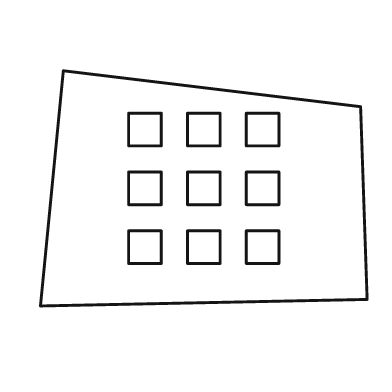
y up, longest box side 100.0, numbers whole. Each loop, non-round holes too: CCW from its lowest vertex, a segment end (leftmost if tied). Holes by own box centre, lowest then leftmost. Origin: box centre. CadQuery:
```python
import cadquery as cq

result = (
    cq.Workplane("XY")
    .moveTo(-50.0, -36.0)
    .lineTo(50.0, -34.0)
    .lineTo(48.0, 25.0)
    .lineTo(-43.0, 36.0)
    .close()
    .moveTo(-23.0, -23.0)
    .lineTo(-13.0, -23.0)
    .lineTo(-13.0, -13.0)
    .lineTo(-23.0, -13.0)
    .close()
    .moveTo(-5.0, -23.0)
    .lineTo(5.0, -23.0)
    .lineTo(5.0, -13.0)
    .lineTo(-5.0, -13.0)
    .close()
    .moveTo(13.0, -23.0)
    .lineTo(23.0, -23.0)
    .lineTo(23.0, -13.0)
    .lineTo(13.0, -13.0)
    .close()
    .moveTo(-23.0, -5.0)
    .lineTo(-13.0, -5.0)
    .lineTo(-13.0, 5.0)
    .lineTo(-23.0, 5.0)
    .close()
    .moveTo(-5.0, -5.0)
    .lineTo(5.0, -5.0)
    .lineTo(5.0, 5.0)
    .lineTo(-5.0, 5.0)
    .close()
    .moveTo(13.0, -5.0)
    .lineTo(23.0, -5.0)
    .lineTo(23.0, 5.0)
    .lineTo(13.0, 5.0)
    .close()
    .moveTo(-23.0, 13.0)
    .lineTo(-13.0, 13.0)
    .lineTo(-13.0, 23.0)
    .lineTo(-23.0, 23.0)
    .close()
    .moveTo(-5.0, 13.0)
    .lineTo(5.0, 13.0)
    .lineTo(5.0, 23.0)
    .lineTo(-5.0, 23.0)
    .close()
    .moveTo(13.0, 13.0)
    .lineTo(23.0, 13.0)
    .lineTo(23.0, 23.0)
    .lineTo(13.0, 23.0)
    .close()
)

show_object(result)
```